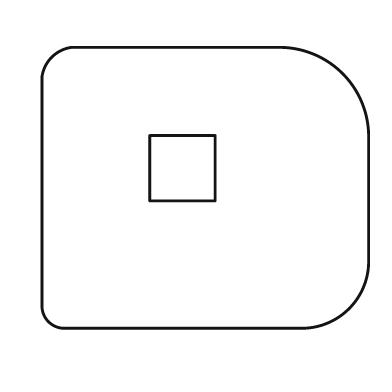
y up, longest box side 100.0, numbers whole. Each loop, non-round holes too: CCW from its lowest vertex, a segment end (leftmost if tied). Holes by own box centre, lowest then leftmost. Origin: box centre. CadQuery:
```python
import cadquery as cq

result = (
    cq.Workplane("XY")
    .moveTo(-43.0, -43.0)
    .lineTo(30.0, -43.0)
    .threePointArc((44.0, -37.0), (50.0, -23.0))
    .lineTo(50.0, 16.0)
    .threePointArc((42.0, 35.0), (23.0, 43.0))
    .lineTo(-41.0, 43.0)
    .threePointArc((-47.0, 40.0), (-50.0, 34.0))
    .lineTo(-50.0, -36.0)
    .threePointArc((-48.0, -41.0), (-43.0, -43.0))
    .close()
    .moveTo(-17.0, -4.0)
    .lineTo(3.0, -4.0)
    .lineTo(3.0, 16.0)
    .lineTo(-17.0, 16.0)
    .close()
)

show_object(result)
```